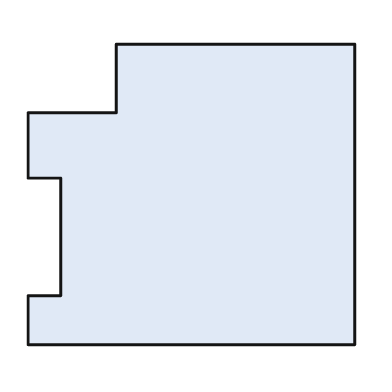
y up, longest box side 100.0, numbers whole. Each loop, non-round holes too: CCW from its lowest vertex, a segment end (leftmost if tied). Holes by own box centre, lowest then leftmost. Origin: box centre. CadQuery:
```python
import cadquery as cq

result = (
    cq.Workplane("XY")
    .moveTo(-50.0, -46.0)
    .lineTo(50.0, -46.0)
    .lineTo(50.0, 46.0)
    .lineTo(-23.0, 46.0)
    .lineTo(-23.0, 25.0)
    .lineTo(-50.0, 25.0)
    .lineTo(-50.0, 5.0)
    .lineTo(-40.0, 5.0)
    .lineTo(-40.0, -31.0)
    .lineTo(-50.0, -31.0)
    .close()
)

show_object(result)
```